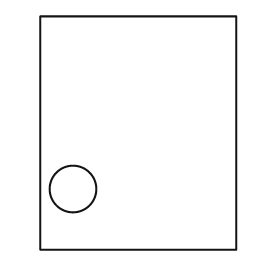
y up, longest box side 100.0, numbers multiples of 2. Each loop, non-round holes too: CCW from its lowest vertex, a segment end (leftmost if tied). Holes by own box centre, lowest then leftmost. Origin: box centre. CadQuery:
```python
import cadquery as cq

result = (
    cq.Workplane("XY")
    .moveTo(-42.0, -50.0)
    .lineTo(42.0, -50.0)
    .lineTo(42.0, 50.0)
    .lineTo(-42.0, 50.0)
    .close()
    .moveTo(-28.0, -24.0)
    .circle(10.0)
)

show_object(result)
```